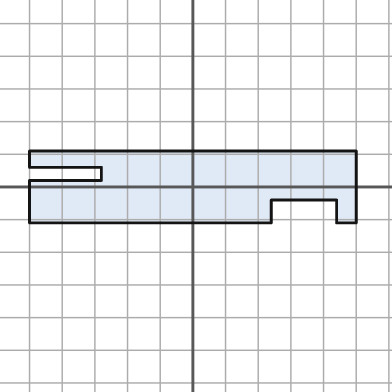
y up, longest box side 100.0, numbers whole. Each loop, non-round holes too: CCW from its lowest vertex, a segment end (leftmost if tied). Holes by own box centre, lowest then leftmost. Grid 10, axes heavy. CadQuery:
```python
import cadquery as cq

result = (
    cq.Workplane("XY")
    .moveTo(-50.0, -11.0)
    .lineTo(24.0, -11.0)
    .lineTo(24.0, -4.0)
    .lineTo(44.0, -4.0)
    .lineTo(44.0, -11.0)
    .lineTo(50.0, -11.0)
    .lineTo(50.0, 11.0)
    .lineTo(-50.0, 11.0)
    .lineTo(-50.0, 6.0)
    .lineTo(-28.0, 6.0)
    .lineTo(-28.0, 2.0)
    .lineTo(-50.0, 2.0)
    .close()
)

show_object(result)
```